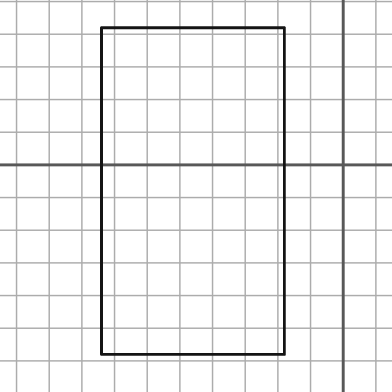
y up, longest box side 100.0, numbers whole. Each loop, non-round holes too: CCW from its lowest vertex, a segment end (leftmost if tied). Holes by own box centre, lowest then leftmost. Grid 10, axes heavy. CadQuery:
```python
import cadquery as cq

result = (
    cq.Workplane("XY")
    .moveTo(-74.0, -58.0)
    .lineTo(-18.0, -58.0)
    .lineTo(-18.0, 42.0)
    .lineTo(-74.0, 42.0)
    .close()
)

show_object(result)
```